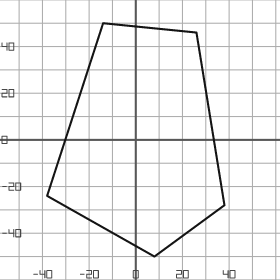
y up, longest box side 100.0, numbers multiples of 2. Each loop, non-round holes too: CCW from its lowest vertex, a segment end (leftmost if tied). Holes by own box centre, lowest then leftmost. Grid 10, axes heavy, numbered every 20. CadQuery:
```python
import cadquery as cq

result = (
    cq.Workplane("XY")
    .moveTo(8.0, -50.0)
    .lineTo(38.0, -28.0)
    .lineTo(26.0, 46.0)
    .lineTo(-14.0, 50.0)
    .lineTo(-38.0, -24.0)
    .close()
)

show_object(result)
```